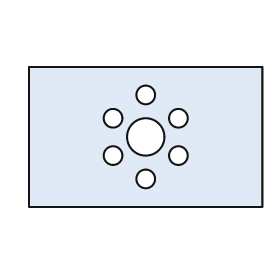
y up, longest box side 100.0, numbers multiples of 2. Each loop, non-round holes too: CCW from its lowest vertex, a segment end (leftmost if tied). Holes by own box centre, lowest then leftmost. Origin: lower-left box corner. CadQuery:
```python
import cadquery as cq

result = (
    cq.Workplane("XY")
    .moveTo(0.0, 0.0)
    .lineTo(100.0, 0.0)
    .lineTo(100.0, 60.0)
    .lineTo(0.0, 60.0)
    .close()
    .moveTo(50.0, 12.0)
    .circle(4.0)
    .moveTo(36.0, 22.0)
    .circle(4.0)
    .moveTo(64.0, 22.0)
    .circle(4.0)
    .moveTo(50.0, 30.0)
    .circle(8.0)
    .moveTo(36.0, 38.0)
    .circle(4.0)
    .moveTo(64.0, 38.0)
    .circle(4.0)
    .moveTo(50.0, 48.0)
    .circle(4.0)
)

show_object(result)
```